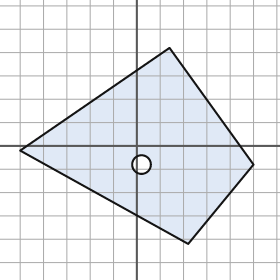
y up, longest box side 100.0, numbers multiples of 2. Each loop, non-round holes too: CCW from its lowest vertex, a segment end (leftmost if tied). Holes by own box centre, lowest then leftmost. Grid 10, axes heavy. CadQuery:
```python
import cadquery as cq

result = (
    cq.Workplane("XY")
    .moveTo(22.0, -42.0)
    .lineTo(50.0, -8.0)
    .lineTo(14.0, 42.0)
    .lineTo(-50.0, -2.0)
    .close()
    .moveTo(2.0, -8.0)
    .circle(4.0)
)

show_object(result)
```